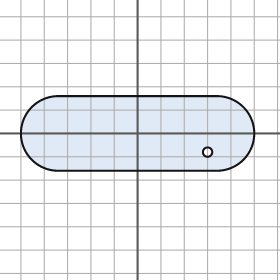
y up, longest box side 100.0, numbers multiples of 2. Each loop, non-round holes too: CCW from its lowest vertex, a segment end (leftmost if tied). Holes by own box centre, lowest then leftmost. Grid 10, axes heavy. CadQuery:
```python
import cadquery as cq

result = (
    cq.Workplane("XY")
    .moveTo(-34.0, -16.0)
    .lineTo(34.0, -16.0)
    .threePointArc((50.0, 0.0), (34.0, 16.0))
    .lineTo(-34.0, 16.0)
    .threePointArc((-50.0, 0.0), (-34.0, -16.0))
    .close()
    .moveTo(30.0, -8.0)
    .circle(2.0)
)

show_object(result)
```